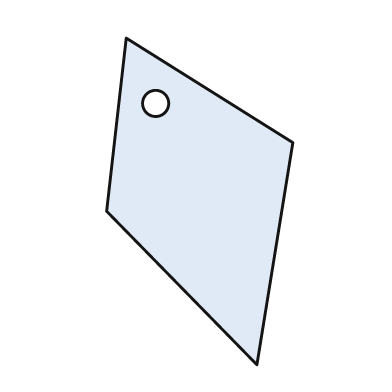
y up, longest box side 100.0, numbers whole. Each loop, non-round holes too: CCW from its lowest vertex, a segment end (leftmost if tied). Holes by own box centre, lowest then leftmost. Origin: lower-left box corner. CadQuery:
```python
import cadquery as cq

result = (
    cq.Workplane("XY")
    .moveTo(46.0, 0.0)
    .lineTo(57.0, 68.0)
    .lineTo(6.0, 100.0)
    .lineTo(0.0, 47.0)
    .close()
    .moveTo(15.0, 80.0)
    .circle(4.0)
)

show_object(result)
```